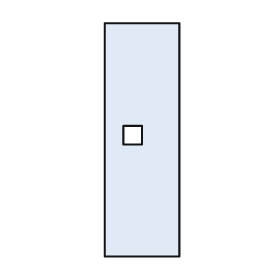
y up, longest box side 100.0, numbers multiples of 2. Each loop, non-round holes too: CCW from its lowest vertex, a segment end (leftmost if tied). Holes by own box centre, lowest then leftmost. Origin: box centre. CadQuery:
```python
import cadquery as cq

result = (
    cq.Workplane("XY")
    .moveTo(-16.0, -50.0)
    .lineTo(16.0, -50.0)
    .lineTo(16.0, 50.0)
    .lineTo(-16.0, 50.0)
    .close()
    .moveTo(-8.0, -2.0)
    .lineTo(0.0, -2.0)
    .lineTo(0.0, 6.0)
    .lineTo(-8.0, 6.0)
    .close()
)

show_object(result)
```